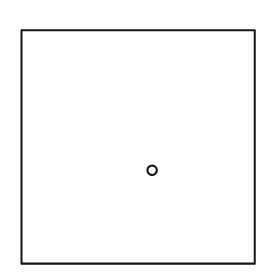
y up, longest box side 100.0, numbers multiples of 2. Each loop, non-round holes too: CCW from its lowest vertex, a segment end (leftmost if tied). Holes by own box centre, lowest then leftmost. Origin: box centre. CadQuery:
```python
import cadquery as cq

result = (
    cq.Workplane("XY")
    .moveTo(-50.0, -50.0)
    .lineTo(50.0, -50.0)
    .lineTo(50.0, 50.0)
    .lineTo(-50.0, 50.0)
    .close()
    .moveTo(6.0, -10.0)
    .circle(2.0)
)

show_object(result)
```